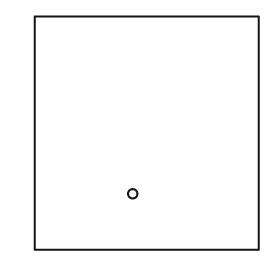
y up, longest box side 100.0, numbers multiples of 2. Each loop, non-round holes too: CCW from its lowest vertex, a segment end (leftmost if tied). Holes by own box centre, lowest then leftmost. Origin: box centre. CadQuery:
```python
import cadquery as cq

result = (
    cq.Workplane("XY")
    .moveTo(-48.0, -50.0)
    .lineTo(48.0, -50.0)
    .lineTo(48.0, 50.0)
    .lineTo(-48.0, 50.0)
    .close()
    .moveTo(-6.0, -26.0)
    .circle(2.0)
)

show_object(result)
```